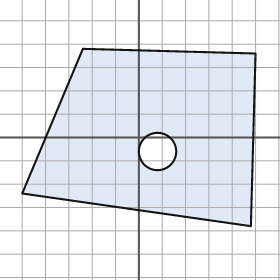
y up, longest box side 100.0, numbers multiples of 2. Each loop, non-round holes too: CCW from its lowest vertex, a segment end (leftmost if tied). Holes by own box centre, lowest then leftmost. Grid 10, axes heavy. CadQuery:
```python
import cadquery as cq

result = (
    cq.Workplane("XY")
    .moveTo(48.0, -38.0)
    .lineTo(50.0, 36.0)
    .lineTo(-24.0, 38.0)
    .lineTo(-50.0, -24.0)
    .close()
    .moveTo(8.0, -6.0)
    .circle(8.0)
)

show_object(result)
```